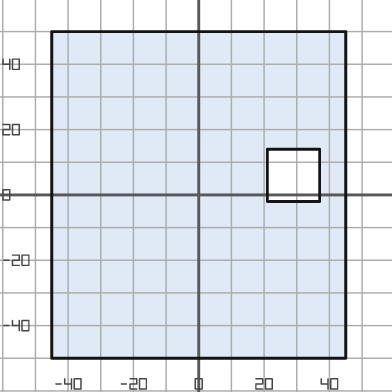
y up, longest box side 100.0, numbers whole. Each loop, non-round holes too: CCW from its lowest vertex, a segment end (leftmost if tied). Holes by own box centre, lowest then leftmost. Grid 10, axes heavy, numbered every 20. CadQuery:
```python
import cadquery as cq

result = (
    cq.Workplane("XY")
    .moveTo(-45.0, -50.0)
    .lineTo(45.0, -50.0)
    .lineTo(45.0, 50.0)
    .lineTo(-45.0, 50.0)
    .close()
    .moveTo(21.0, -2.0)
    .lineTo(37.0, -2.0)
    .lineTo(37.0, 14.0)
    .lineTo(21.0, 14.0)
    .close()
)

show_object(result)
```